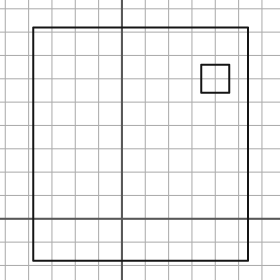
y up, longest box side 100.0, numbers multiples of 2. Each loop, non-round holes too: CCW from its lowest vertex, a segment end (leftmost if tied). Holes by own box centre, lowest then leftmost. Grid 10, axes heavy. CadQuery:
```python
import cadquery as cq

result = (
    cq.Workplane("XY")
    .moveTo(-38.0, -18.0)
    .lineTo(54.0, -18.0)
    .lineTo(54.0, 82.0)
    .lineTo(-38.0, 82.0)
    .close()
    .moveTo(34.0, 54.0)
    .lineTo(46.0, 54.0)
    .lineTo(46.0, 66.0)
    .lineTo(34.0, 66.0)
    .close()
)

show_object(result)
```